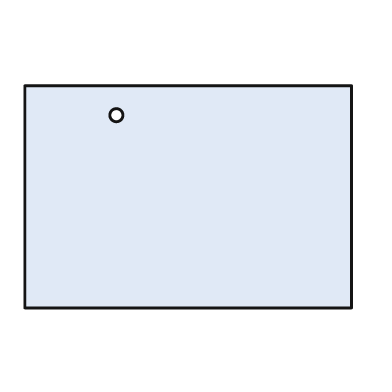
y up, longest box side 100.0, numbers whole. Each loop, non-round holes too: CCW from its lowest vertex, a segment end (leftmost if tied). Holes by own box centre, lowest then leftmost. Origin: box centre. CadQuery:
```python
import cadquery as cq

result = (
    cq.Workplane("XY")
    .moveTo(-50.0, -34.0)
    .lineTo(50.0, -34.0)
    .lineTo(50.0, 34.0)
    .lineTo(-50.0, 34.0)
    .close()
    .moveTo(-22.0, 25.0)
    .circle(2.0)
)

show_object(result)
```